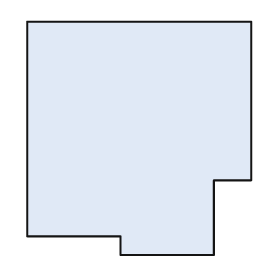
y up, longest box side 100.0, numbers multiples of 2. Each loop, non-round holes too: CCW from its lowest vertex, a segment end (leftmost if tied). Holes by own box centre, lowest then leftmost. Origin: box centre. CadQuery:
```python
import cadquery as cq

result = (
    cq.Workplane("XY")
    .moveTo(-8.0, -50.0)
    .lineTo(32.0, -50.0)
    .lineTo(32.0, -18.0)
    .lineTo(48.0, -18.0)
    .lineTo(48.0, 50.0)
    .lineTo(-48.0, 50.0)
    .lineTo(-48.0, -42.0)
    .lineTo(-8.0, -42.0)
    .close()
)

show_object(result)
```